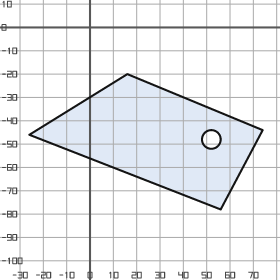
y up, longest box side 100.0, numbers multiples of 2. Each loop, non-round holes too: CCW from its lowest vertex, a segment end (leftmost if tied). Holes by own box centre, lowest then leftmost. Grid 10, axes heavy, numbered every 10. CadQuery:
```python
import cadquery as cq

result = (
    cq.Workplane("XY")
    .moveTo(56.0, -78.0)
    .lineTo(74.0, -44.0)
    .lineTo(16.0, -20.0)
    .lineTo(-26.0, -46.0)
    .close()
    .moveTo(52.0, -48.0)
    .circle(4.0)
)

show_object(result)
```